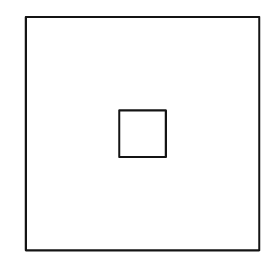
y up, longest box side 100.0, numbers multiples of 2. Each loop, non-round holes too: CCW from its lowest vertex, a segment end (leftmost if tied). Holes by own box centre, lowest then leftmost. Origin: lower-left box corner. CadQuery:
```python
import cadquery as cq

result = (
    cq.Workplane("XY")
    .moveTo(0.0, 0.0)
    .lineTo(100.0, 0.0)
    .lineTo(100.0, 100.0)
    .lineTo(0.0, 100.0)
    .close()
    .moveTo(40.0, 40.0)
    .lineTo(60.0, 40.0)
    .lineTo(60.0, 60.0)
    .lineTo(40.0, 60.0)
    .close()
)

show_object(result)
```